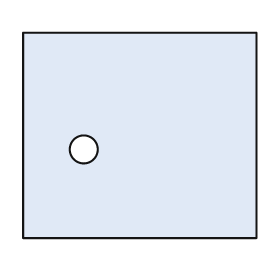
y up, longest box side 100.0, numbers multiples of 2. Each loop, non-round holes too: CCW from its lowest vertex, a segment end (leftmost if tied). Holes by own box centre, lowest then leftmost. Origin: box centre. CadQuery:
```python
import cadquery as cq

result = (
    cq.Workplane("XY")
    .moveTo(-50.0, -44.0)
    .lineTo(50.0, -44.0)
    .lineTo(50.0, 44.0)
    .lineTo(-50.0, 44.0)
    .close()
    .moveTo(-24.0, -6.0)
    .circle(6.0)
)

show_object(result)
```